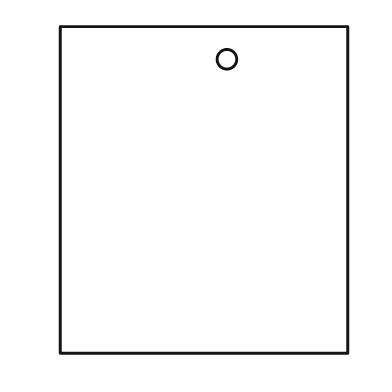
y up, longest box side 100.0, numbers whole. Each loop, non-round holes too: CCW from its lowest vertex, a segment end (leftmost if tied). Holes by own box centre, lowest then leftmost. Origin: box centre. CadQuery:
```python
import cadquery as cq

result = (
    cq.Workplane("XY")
    .moveTo(-44.0, -50.0)
    .lineTo(44.0, -50.0)
    .lineTo(44.0, 50.0)
    .lineTo(-44.0, 50.0)
    .close()
    .moveTo(7.0, 40.0)
    .circle(3.0)
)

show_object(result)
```